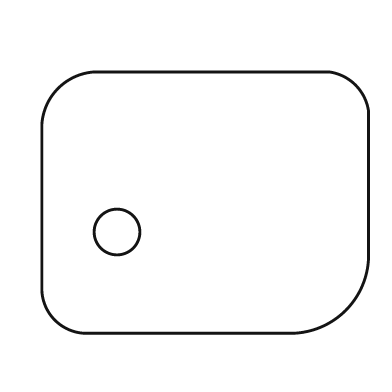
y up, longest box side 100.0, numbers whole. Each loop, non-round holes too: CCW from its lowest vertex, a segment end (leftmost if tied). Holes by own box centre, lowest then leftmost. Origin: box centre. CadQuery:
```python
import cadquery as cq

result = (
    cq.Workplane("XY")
    .moveTo(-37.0, -40.0)
    .lineTo(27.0, -40.0)
    .threePointArc((43.0, -33.0), (50.0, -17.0))
    .lineTo(50.0, 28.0)
    .threePointArc((46.0, 36.0), (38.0, 40.0))
    .lineTo(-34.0, 40.0)
    .threePointArc((-45.0, 35.0), (-50.0, 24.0))
    .lineTo(-50.0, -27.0)
    .threePointArc((-46.0, -36.0), (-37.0, -40.0))
    .close()
    .moveTo(-27.0, -9.0)
    .circle(7.0)
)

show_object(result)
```